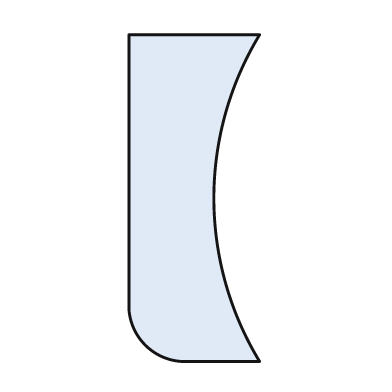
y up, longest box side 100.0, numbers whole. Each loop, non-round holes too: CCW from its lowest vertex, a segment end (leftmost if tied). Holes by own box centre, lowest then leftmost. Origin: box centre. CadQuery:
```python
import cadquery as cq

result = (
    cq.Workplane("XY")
    .moveTo(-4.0, -50.0)
    .lineTo(20.0, -50.0)
    .threePointArc((6.0, 0.0), (20.0, 50.0))
    .lineTo(-20.0, 50.0)
    .lineTo(-20.0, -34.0)
    .threePointArc((-15.0, -45.0), (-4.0, -50.0))
    .close()
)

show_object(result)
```